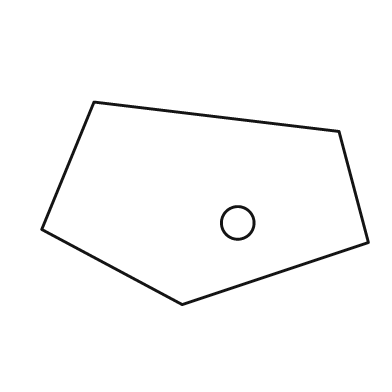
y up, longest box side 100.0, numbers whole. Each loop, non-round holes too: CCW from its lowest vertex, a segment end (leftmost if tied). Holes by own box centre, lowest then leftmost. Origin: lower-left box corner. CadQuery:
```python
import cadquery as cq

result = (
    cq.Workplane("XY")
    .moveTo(43.0, 0.0)
    .lineTo(100.0, 19.0)
    .lineTo(91.0, 53.0)
    .lineTo(16.0, 62.0)
    .lineTo(0.0, 23.0)
    .close()
    .moveTo(60.0, 25.0)
    .circle(5.0)
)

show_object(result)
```